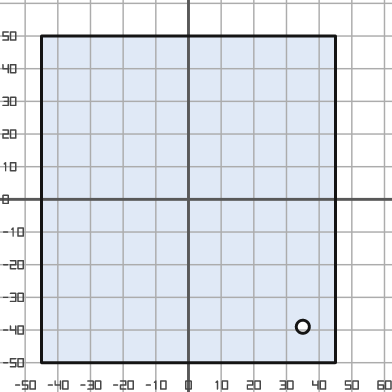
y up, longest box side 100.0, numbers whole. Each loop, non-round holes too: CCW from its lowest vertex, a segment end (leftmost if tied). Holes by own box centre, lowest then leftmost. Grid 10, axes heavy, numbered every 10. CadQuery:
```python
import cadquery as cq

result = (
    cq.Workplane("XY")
    .moveTo(-45.0, -50.0)
    .lineTo(45.0, -50.0)
    .lineTo(45.0, 50.0)
    .lineTo(-45.0, 50.0)
    .close()
    .moveTo(35.0, -39.0)
    .circle(2.0)
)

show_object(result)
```